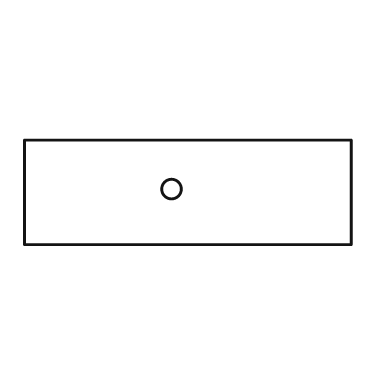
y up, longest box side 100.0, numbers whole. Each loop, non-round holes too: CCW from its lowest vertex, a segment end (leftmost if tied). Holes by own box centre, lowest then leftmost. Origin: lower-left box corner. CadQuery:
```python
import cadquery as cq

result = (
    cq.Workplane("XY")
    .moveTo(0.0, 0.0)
    .lineTo(100.0, 0.0)
    .lineTo(100.0, 32.0)
    .lineTo(0.0, 32.0)
    .close()
    .moveTo(45.0, 17.0)
    .circle(3.0)
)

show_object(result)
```